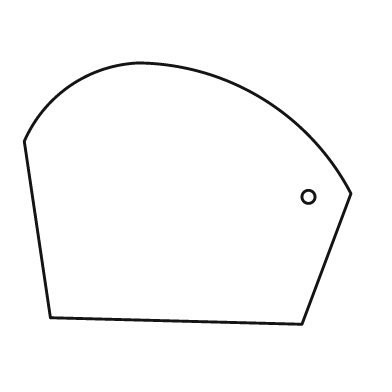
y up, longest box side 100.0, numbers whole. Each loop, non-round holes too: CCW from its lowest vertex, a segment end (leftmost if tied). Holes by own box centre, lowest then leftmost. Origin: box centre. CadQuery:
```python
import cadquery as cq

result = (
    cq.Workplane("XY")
    .moveTo(35.0, -40.0)
    .lineTo(50.0, 0.0)
    .threePointArc((23.0, 29.0), (-15.0, 40.0))
    .threePointArc((-36.0, 33.0), (-50.0, 16.0))
    .lineTo(-42.0, -38.0)
    .close()
    .moveTo(37.0, -1.0)
    .circle(2.0)
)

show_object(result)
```